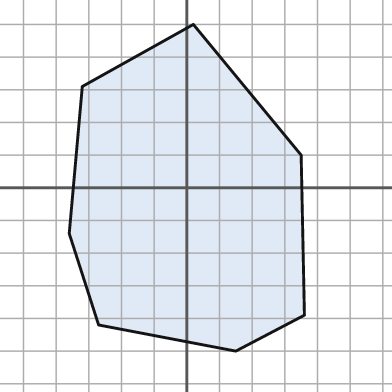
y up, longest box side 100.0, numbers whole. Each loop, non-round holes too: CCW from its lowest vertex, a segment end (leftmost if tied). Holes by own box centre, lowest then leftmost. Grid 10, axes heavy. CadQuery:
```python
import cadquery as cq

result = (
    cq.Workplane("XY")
    .moveTo(15.0, -50.0)
    .lineTo(36.0, -39.0)
    .lineTo(35.0, 10.0)
    .lineTo(2.0, 50.0)
    .lineTo(-32.0, 31.0)
    .lineTo(-36.0, -14.0)
    .lineTo(-27.0, -42.0)
    .close()
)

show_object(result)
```